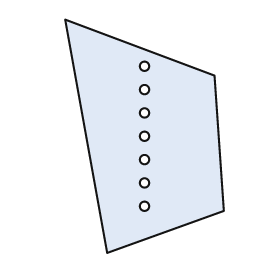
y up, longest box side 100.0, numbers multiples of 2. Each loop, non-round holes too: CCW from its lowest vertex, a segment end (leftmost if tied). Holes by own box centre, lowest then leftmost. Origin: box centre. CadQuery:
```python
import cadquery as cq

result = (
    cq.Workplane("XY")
    .moveTo(-16.0, -50.0)
    .lineTo(34.0, -32.0)
    .lineTo(30.0, 26.0)
    .lineTo(-34.0, 50.0)
    .close()
    .moveTo(0.0, -30.0)
    .circle(2.0)
    .moveTo(0.0, -20.0)
    .circle(2.0)
    .moveTo(0.0, -10.0)
    .circle(2.0)
    .moveTo(0.0, 0.0)
    .circle(2.0)
    .moveTo(0.0, 10.0)
    .circle(2.0)
    .moveTo(0.0, 20.0)
    .circle(2.0)
    .moveTo(0.0, 30.0)
    .circle(2.0)
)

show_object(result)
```